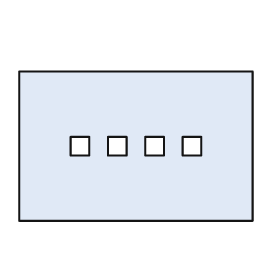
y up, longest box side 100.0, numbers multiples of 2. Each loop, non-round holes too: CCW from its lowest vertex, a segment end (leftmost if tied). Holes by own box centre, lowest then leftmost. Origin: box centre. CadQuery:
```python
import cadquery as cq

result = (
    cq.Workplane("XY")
    .moveTo(-50.0, -32.0)
    .lineTo(50.0, -32.0)
    .lineTo(50.0, 32.0)
    .lineTo(-50.0, 32.0)
    .close()
    .moveTo(-28.0, -4.0)
    .lineTo(-20.0, -4.0)
    .lineTo(-20.0, 4.0)
    .lineTo(-28.0, 4.0)
    .close()
    .moveTo(-12.0, -4.0)
    .lineTo(-4.0, -4.0)
    .lineTo(-4.0, 4.0)
    .lineTo(-12.0, 4.0)
    .close()
    .moveTo(4.0, -4.0)
    .lineTo(12.0, -4.0)
    .lineTo(12.0, 4.0)
    .lineTo(4.0, 4.0)
    .close()
    .moveTo(20.0, -4.0)
    .lineTo(28.0, -4.0)
    .lineTo(28.0, 4.0)
    .lineTo(20.0, 4.0)
    .close()
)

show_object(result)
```